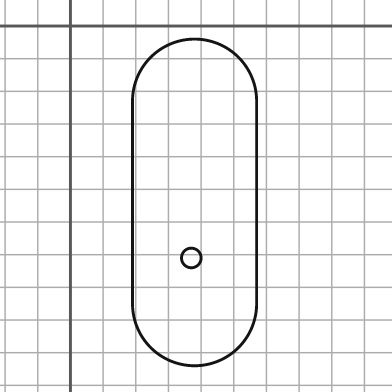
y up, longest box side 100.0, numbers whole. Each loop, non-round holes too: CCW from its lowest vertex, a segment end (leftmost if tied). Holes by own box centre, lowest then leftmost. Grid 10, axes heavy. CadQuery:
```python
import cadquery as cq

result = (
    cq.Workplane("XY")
    .moveTo(19.0, -85.0)
    .threePointArc((38.0, -104.0), (57.0, -85.0))
    .lineTo(57.0, -23.0)
    .threePointArc((38.0, -4.0), (19.0, -23.0))
    .close()
    .moveTo(37.0, -71.0)
    .circle(3.0)
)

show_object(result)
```